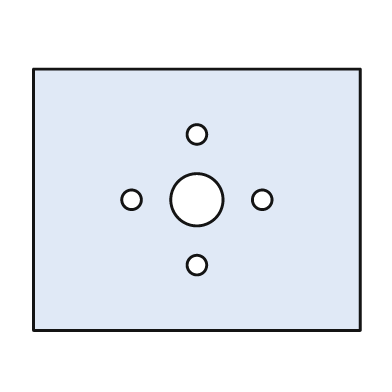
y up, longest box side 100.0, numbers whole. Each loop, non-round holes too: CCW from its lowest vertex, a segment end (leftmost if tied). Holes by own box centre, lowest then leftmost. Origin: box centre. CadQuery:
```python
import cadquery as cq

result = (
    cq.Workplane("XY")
    .moveTo(-50.0, -40.0)
    .lineTo(50.0, -40.0)
    .lineTo(50.0, 40.0)
    .lineTo(-50.0, 40.0)
    .close()
    .moveTo(0.0, -20.0)
    .circle(3.0)
    .moveTo(-20.0, 0.0)
    .circle(3.0)
    .moveTo(0.0, 0.0)
    .circle(8.0)
    .moveTo(20.0, 0.0)
    .circle(3.0)
    .moveTo(0.0, 20.0)
    .circle(3.0)
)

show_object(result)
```